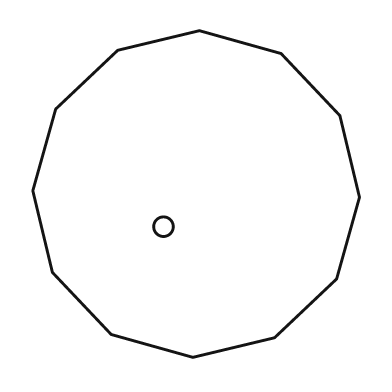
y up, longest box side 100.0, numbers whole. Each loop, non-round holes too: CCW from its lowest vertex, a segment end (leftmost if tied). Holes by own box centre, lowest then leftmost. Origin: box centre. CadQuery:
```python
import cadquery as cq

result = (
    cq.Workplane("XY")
    .moveTo(-1.0, -50.0)
    .lineTo(24.0, -44.0)
    .lineTo(43.0, -26.0)
    .lineTo(50.0, -1.0)
    .lineTo(44.0, 24.0)
    .lineTo(26.0, 43.0)
    .lineTo(1.0, 50.0)
    .lineTo(-24.0, 44.0)
    .lineTo(-43.0, 26.0)
    .lineTo(-50.0, 1.0)
    .lineTo(-44.0, -24.0)
    .lineTo(-26.0, -43.0)
    .close()
    .moveTo(-10.0, -10.0)
    .circle(3.0)
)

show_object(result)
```